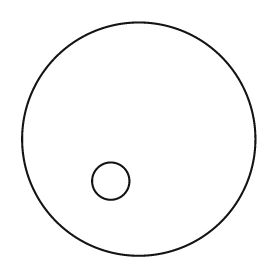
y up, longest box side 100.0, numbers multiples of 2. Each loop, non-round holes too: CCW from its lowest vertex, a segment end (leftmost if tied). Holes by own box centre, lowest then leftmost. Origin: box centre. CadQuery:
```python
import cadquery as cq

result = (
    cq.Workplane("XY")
    .moveTo(0.0, 0.0)
    .circle(50.0)
    .moveTo(-12.0, -18.0)
    .circle(8.0)
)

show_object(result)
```